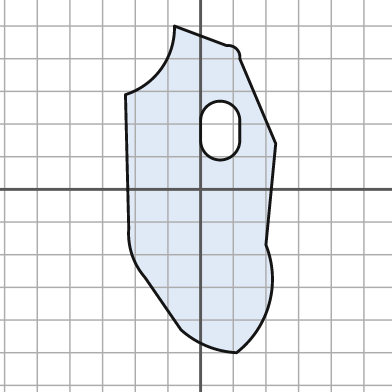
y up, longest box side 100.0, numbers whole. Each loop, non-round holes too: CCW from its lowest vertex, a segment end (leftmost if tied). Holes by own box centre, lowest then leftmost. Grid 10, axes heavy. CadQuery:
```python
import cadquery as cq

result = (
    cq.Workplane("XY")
    .moveTo(11.0, -50.0)
    .threePointArc((21.0, -35.0), (20.0, -17.0))
    .lineTo(23.0, 14.0)
    .lineTo(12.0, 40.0)
    .threePointArc((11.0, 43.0), (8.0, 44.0))
    .lineTo(-8.0, 50.0)
    .threePointArc((-12.0, 37.0), (-23.0, 29.0))
    .lineTo(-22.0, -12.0)
    .threePointArc((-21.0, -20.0), (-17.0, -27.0))
    .lineTo(-6.0, -43.0)
    .threePointArc((2.0, -48.0), (11.0, -50.0))
    .close()
    .moveTo(0.0, 15.0)
    .threePointArc((6.0, 9.0), (12.0, 15.0))
    .lineTo(12.0, 21.0)
    .threePointArc((6.0, 27.0), (0.0, 21.0))
    .close()
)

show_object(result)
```